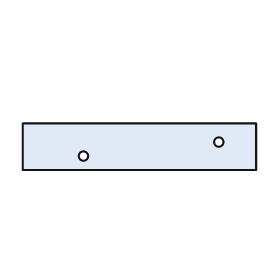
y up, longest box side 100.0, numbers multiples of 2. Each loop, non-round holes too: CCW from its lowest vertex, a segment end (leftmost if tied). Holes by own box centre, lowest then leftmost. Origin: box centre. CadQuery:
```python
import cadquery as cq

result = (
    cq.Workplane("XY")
    .moveTo(-50.0, -10.0)
    .lineTo(50.0, -10.0)
    .lineTo(50.0, 10.0)
    .lineTo(-50.0, 10.0)
    .close()
    .moveTo(-24.0, -4.0)
    .circle(2.0)
    .moveTo(34.0, 2.0)
    .circle(2.0)
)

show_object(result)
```